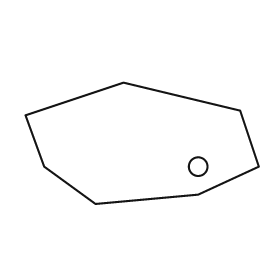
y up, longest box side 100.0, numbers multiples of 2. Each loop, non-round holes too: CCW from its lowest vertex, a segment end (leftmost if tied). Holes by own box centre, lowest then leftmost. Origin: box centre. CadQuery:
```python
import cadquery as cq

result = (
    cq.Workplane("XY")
    .moveTo(-20.0, -26.0)
    .lineTo(24.0, -22.0)
    .lineTo(50.0, -10.0)
    .lineTo(42.0, 14.0)
    .lineTo(-8.0, 26.0)
    .lineTo(-50.0, 12.0)
    .lineTo(-42.0, -10.0)
    .close()
    .moveTo(24.0, -10.0)
    .circle(4.0)
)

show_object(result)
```